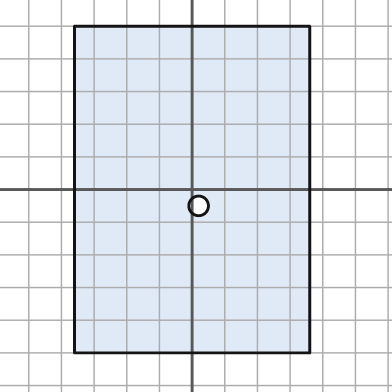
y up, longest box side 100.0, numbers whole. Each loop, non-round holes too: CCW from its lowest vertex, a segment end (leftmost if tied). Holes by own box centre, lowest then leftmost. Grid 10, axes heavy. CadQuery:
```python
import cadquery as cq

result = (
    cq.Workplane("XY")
    .moveTo(-36.0, -50.0)
    .lineTo(36.0, -50.0)
    .lineTo(36.0, 50.0)
    .lineTo(-36.0, 50.0)
    .close()
    .moveTo(2.0, -5.0)
    .circle(3.0)
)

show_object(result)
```